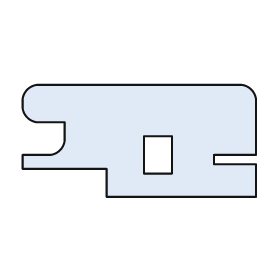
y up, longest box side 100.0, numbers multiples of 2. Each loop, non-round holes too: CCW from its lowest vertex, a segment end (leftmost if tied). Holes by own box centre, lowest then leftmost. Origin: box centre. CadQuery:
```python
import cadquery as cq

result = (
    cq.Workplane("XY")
    .moveTo(-14.0, -24.0)
    .lineTo(50.0, -24.0)
    .lineTo(50.0, -10.0)
    .lineTo(32.0, -10.0)
    .lineTo(32.0, -6.0)
    .lineTo(50.0, -6.0)
    .lineTo(50.0, 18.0)
    .threePointArc((48.0, 22.0), (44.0, 24.0))
    .lineTo(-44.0, 24.0)
    .threePointArc((-48.0, 22.0), (-50.0, 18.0))
    .lineTo(-50.0, 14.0)
    .threePointArc((-48.0, 10.0), (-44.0, 8.0))
    .lineTo(-32.0, 8.0)
    .lineTo(-32.0, 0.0)
    .threePointArc((-34.0, -4.0), (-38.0, -6.0))
    .lineTo(-50.0, -6.0)
    .lineTo(-50.0, -12.0)
    .lineTo(-14.0, -12.0)
    .close()
    .moveTo(2.0, -14.0)
    .lineTo(14.0, -14.0)
    .lineTo(14.0, 2.0)
    .lineTo(2.0, 2.0)
    .close()
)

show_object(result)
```